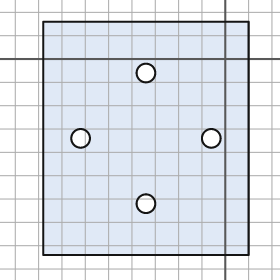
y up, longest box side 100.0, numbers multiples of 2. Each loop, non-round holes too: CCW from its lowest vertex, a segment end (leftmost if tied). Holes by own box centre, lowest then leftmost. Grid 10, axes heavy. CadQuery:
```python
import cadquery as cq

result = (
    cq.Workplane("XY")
    .moveTo(-78.0, -84.0)
    .lineTo(10.0, -84.0)
    .lineTo(10.0, 16.0)
    .lineTo(-78.0, 16.0)
    .close()
    .moveTo(-34.0, -62.0)
    .circle(4.0)
    .moveTo(-62.0, -34.0)
    .circle(4.0)
    .moveTo(-6.0, -34.0)
    .circle(4.0)
    .moveTo(-34.0, -6.0)
    .circle(4.0)
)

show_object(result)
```